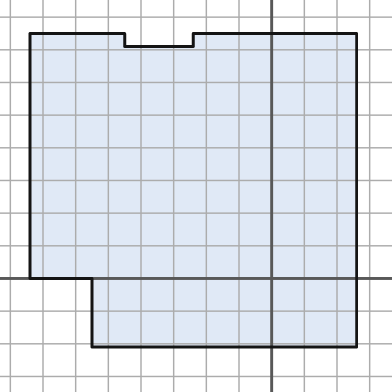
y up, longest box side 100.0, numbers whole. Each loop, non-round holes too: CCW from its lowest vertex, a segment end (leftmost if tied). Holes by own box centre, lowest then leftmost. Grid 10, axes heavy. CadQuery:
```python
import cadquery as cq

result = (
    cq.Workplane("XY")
    .moveTo(-55.0, -21.0)
    .lineTo(26.0, -21.0)
    .lineTo(26.0, 75.0)
    .lineTo(-24.0, 75.0)
    .lineTo(-24.0, 71.0)
    .lineTo(-45.0, 71.0)
    .lineTo(-45.0, 75.0)
    .lineTo(-74.0, 75.0)
    .lineTo(-74.0, 0.0)
    .lineTo(-55.0, 0.0)
    .close()
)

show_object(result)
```